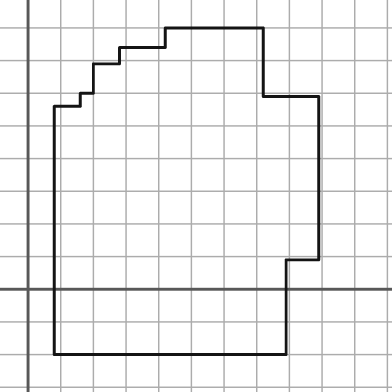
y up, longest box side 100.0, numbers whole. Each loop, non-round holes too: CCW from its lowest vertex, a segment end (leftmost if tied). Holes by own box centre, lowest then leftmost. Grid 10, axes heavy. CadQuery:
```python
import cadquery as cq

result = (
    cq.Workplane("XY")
    .moveTo(8.0, -20.0)
    .lineTo(79.0, -20.0)
    .lineTo(79.0, 9.0)
    .lineTo(89.0, 9.0)
    .lineTo(89.0, 59.0)
    .lineTo(72.0, 59.0)
    .lineTo(72.0, 80.0)
    .lineTo(42.0, 80.0)
    .lineTo(42.0, 74.0)
    .lineTo(28.0, 74.0)
    .lineTo(28.0, 69.0)
    .lineTo(20.0, 69.0)
    .lineTo(20.0, 60.0)
    .lineTo(16.0, 60.0)
    .lineTo(16.0, 56.0)
    .lineTo(8.0, 56.0)
    .close()
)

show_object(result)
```